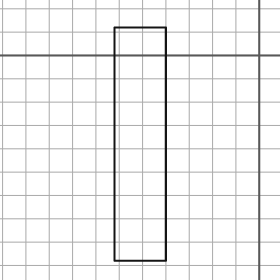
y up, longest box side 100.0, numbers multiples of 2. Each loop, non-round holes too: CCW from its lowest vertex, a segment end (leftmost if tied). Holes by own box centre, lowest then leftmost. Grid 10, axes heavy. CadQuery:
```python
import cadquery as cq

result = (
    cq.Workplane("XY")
    .moveTo(-62.0, -88.0)
    .lineTo(-40.0, -88.0)
    .lineTo(-40.0, 12.0)
    .lineTo(-62.0, 12.0)
    .close()
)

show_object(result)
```